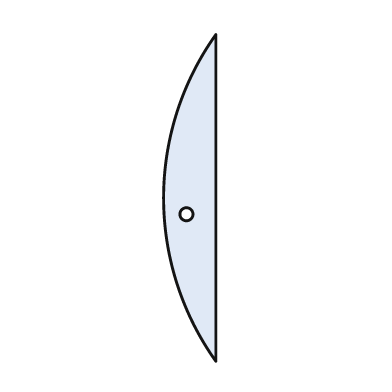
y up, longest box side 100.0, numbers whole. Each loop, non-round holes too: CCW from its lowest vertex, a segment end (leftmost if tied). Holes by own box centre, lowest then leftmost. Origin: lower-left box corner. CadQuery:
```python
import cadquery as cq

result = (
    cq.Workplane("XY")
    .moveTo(16.0, 0.0)
    .lineTo(16.0, 100.0)
    .threePointArc((0.0, 50.0), (16.0, 0.0))
    .close()
    .moveTo(7.0, 45.0)
    .circle(2.0)
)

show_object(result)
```